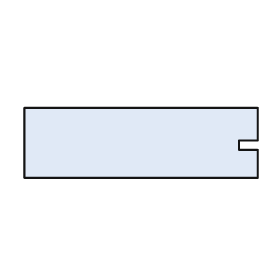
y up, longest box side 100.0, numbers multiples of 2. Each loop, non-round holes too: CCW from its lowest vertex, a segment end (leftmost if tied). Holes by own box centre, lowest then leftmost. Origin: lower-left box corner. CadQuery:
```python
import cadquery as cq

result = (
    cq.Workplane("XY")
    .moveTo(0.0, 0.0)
    .lineTo(100.0, 0.0)
    .lineTo(100.0, 12.0)
    .lineTo(92.0, 12.0)
    .lineTo(92.0, 16.0)
    .lineTo(100.0, 16.0)
    .lineTo(100.0, 30.0)
    .lineTo(0.0, 30.0)
    .close()
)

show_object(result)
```